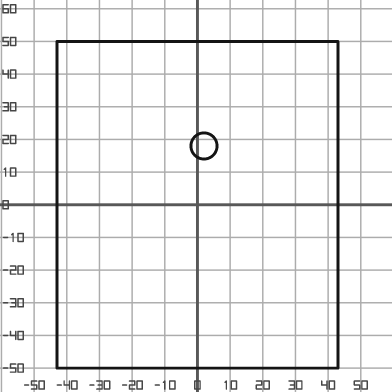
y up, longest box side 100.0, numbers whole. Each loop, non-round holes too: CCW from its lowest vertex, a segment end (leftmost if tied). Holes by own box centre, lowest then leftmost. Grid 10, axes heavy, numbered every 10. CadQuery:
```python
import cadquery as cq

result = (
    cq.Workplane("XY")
    .moveTo(-43.0, -50.0)
    .lineTo(43.0, -50.0)
    .lineTo(43.0, 50.0)
    .lineTo(-43.0, 50.0)
    .close()
    .moveTo(2.0, 18.0)
    .circle(4.0)
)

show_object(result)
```